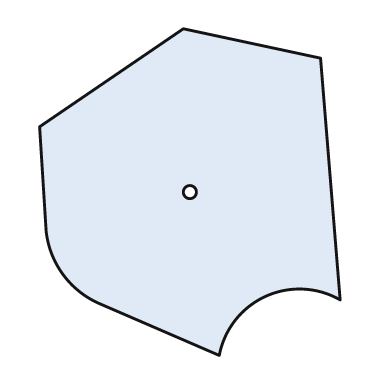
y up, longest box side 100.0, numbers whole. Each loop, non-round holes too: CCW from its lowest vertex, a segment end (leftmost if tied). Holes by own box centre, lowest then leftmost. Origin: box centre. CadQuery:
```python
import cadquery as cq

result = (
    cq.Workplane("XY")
    .moveTo(9.0, -50.0)
    .threePointArc((23.0, -32.0), (46.0, -33.0))
    .lineTo(40.0, 41.0)
    .lineTo(-2.0, 50.0)
    .lineTo(-46.0, 20.0)
    .lineTo(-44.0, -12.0)
    .threePointArc((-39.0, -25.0), (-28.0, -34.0))
    .close()
    .moveTo(0.0, 0.0)
    .circle(2.0)
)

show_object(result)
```